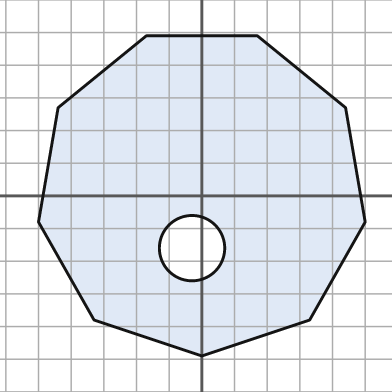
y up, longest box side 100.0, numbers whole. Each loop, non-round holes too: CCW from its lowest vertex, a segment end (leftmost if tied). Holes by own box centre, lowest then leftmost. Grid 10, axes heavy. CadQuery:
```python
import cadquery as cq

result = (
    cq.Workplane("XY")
    .moveTo(0.0, -49.0)
    .lineTo(33.0, -38.0)
    .lineTo(50.0, -8.0)
    .lineTo(44.0, 27.0)
    .lineTo(17.0, 49.0)
    .lineTo(-17.0, 49.0)
    .lineTo(-44.0, 27.0)
    .lineTo(-50.0, -8.0)
    .lineTo(-33.0, -38.0)
    .close()
    .moveTo(-3.0, -16.0)
    .circle(10.0)
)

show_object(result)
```